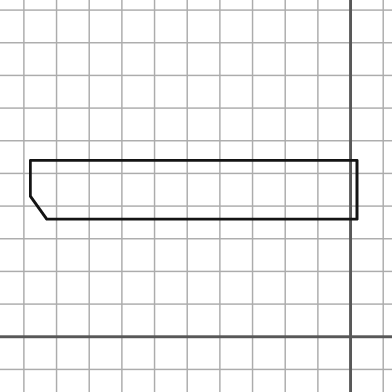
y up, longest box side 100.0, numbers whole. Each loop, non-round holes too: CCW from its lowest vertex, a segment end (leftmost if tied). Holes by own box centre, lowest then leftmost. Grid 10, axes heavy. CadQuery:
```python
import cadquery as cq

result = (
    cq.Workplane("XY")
    .moveTo(-93.0, 36.0)
    .lineTo(2.0, 36.0)
    .lineTo(2.0, 54.0)
    .lineTo(-98.0, 54.0)
    .lineTo(-98.0, 43.0)
    .close()
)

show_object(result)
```